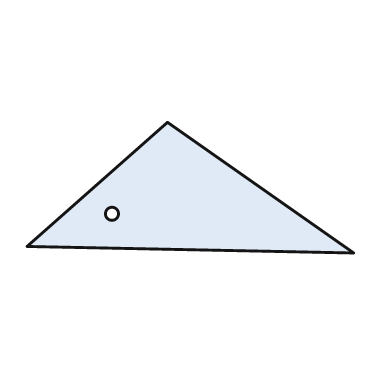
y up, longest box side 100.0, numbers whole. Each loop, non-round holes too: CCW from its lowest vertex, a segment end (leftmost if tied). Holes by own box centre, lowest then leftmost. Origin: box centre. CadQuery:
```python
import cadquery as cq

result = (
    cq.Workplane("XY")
    .moveTo(50.0, -20.0)
    .lineTo(-7.0, 20.0)
    .lineTo(-50.0, -18.0)
    .close()
    .moveTo(-24.0, -8.0)
    .circle(2.0)
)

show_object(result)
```